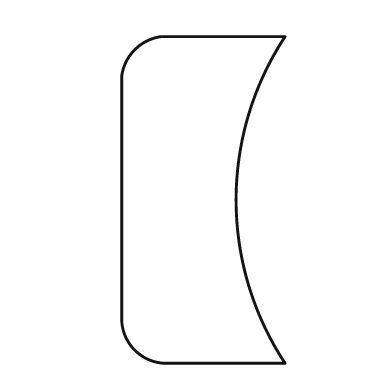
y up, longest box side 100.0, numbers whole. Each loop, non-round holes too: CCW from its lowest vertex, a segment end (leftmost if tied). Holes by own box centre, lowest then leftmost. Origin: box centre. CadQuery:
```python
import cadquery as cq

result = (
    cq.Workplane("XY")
    .moveTo(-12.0, -50.0)
    .lineTo(25.0, -50.0)
    .threePointArc((10.0, 0.0), (25.0, 50.0))
    .lineTo(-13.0, 50.0)
    .threePointArc((-21.0, 46.0), (-25.0, 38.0))
    .lineTo(-25.0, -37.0)
    .threePointArc((-21.0, -46.0), (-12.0, -50.0))
    .close()
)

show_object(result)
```